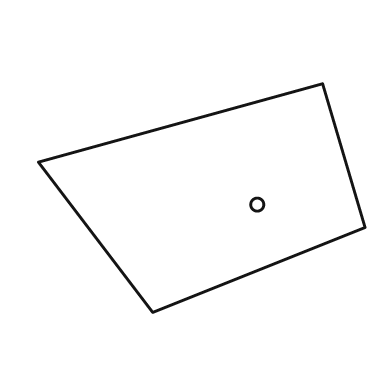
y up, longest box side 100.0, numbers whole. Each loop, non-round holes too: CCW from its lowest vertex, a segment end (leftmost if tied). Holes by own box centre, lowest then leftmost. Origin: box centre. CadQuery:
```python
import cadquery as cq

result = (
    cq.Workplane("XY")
    .moveTo(-15.0, -35.0)
    .lineTo(50.0, -9.0)
    .lineTo(37.0, 35.0)
    .lineTo(-50.0, 11.0)
    .close()
    .moveTo(17.0, -2.0)
    .circle(2.0)
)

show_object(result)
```